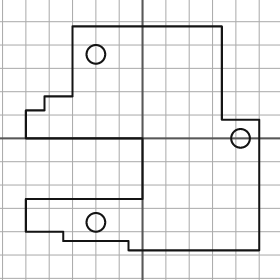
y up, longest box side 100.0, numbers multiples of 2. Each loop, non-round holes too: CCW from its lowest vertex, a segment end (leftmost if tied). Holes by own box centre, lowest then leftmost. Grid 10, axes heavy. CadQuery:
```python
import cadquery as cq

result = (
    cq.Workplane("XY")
    .moveTo(-6.0, -48.0)
    .lineTo(50.0, -48.0)
    .lineTo(50.0, 8.0)
    .lineTo(34.0, 8.0)
    .lineTo(34.0, 48.0)
    .lineTo(-30.0, 48.0)
    .lineTo(-30.0, 18.0)
    .lineTo(-42.0, 18.0)
    .lineTo(-42.0, 12.0)
    .lineTo(-50.0, 12.0)
    .lineTo(-50.0, 0.0)
    .lineTo(0.0, 0.0)
    .lineTo(0.0, -26.0)
    .lineTo(-50.0, -26.0)
    .lineTo(-50.0, -40.0)
    .lineTo(-34.0, -40.0)
    .lineTo(-34.0, -44.0)
    .lineTo(-6.0, -44.0)
    .close()
    .moveTo(-20.0, -36.0)
    .circle(4.0)
    .moveTo(42.0, 0.0)
    .circle(4.0)
    .moveTo(-20.0, 36.0)
    .circle(4.0)
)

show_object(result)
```